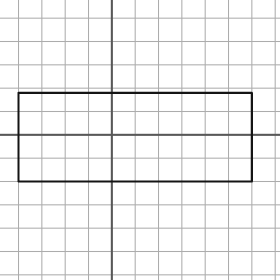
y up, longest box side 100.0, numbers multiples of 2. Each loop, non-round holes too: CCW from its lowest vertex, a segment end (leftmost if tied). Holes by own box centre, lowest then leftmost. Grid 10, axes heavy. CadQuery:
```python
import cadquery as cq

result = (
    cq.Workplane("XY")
    .moveTo(-40.0, -20.0)
    .lineTo(60.0, -20.0)
    .lineTo(60.0, 18.0)
    .lineTo(-40.0, 18.0)
    .close()
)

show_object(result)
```